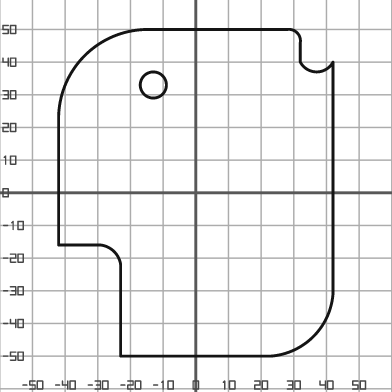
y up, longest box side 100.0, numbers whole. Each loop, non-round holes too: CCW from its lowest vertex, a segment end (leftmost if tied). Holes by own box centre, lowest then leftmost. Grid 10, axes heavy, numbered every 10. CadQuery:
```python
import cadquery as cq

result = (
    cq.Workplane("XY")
    .moveTo(-23.0, -50.0)
    .lineTo(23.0, -50.0)
    .threePointArc((36.0, -44.0), (42.0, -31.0))
    .lineTo(42.0, 40.0)
    .threePointArc((37.0, 37.0), (32.0, 40.0))
    .lineTo(32.0, 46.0)
    .threePointArc((31.0, 49.0), (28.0, 50.0))
    .lineTo(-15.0, 50.0)
    .threePointArc((-34.0, 42.0), (-42.0, 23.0))
    .lineTo(-42.0, -16.0)
    .lineTo(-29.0, -16.0)
    .threePointArc((-25.0, -18.0), (-23.0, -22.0))
    .close()
    .moveTo(-13.0, 33.0)
    .circle(4.0)
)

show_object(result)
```